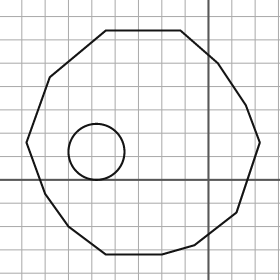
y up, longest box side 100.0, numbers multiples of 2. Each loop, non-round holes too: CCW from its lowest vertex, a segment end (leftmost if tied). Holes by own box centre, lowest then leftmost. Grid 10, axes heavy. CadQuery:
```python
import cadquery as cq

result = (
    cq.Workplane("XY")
    .moveTo(-44.0, -32.0)
    .lineTo(-20.0, -32.0)
    .lineTo(-6.0, -28.0)
    .lineTo(12.0, -14.0)
    .lineTo(22.0, 16.0)
    .lineTo(16.0, 32.0)
    .lineTo(4.0, 50.0)
    .lineTo(-12.0, 64.0)
    .lineTo(-44.0, 64.0)
    .lineTo(-68.0, 44.0)
    .lineTo(-78.0, 16.0)
    .lineTo(-70.0, -6.0)
    .lineTo(-60.0, -20.0)
    .close()
    .moveTo(-48.0, 12.0)
    .circle(12.0)
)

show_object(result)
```